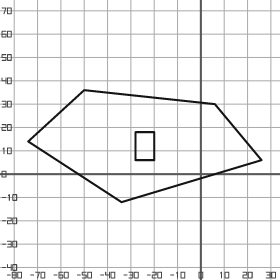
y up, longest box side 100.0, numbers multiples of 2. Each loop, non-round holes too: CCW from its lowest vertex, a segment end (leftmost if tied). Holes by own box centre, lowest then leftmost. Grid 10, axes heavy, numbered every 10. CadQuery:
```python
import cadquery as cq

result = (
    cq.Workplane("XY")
    .moveTo(-34.0, -12.0)
    .lineTo(26.0, 6.0)
    .lineTo(6.0, 30.0)
    .lineTo(-50.0, 36.0)
    .lineTo(-74.0, 14.0)
    .close()
    .moveTo(-28.0, 6.0)
    .lineTo(-20.0, 6.0)
    .lineTo(-20.0, 18.0)
    .lineTo(-28.0, 18.0)
    .close()
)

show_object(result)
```